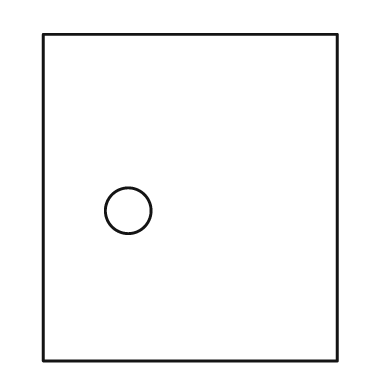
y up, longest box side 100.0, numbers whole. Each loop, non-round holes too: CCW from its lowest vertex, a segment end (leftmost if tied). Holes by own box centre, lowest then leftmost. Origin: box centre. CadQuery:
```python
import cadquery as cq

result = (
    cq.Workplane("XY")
    .moveTo(-45.0, -50.0)
    .lineTo(45.0, -50.0)
    .lineTo(45.0, 50.0)
    .lineTo(-45.0, 50.0)
    .close()
    .moveTo(-19.0, -4.0)
    .circle(7.0)
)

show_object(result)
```